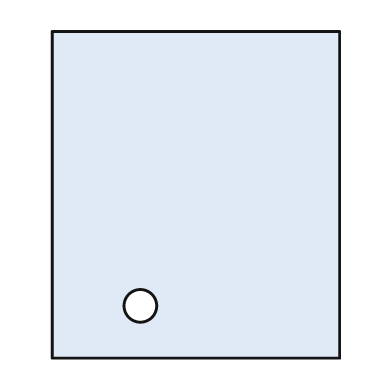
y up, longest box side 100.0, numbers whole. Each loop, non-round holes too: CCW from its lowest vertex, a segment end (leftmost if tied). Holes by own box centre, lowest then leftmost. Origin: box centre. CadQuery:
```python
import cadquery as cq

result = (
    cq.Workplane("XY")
    .moveTo(-44.0, -50.0)
    .lineTo(44.0, -50.0)
    .lineTo(44.0, 50.0)
    .lineTo(-44.0, 50.0)
    .close()
    .moveTo(-17.0, -34.0)
    .circle(5.0)
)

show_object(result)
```